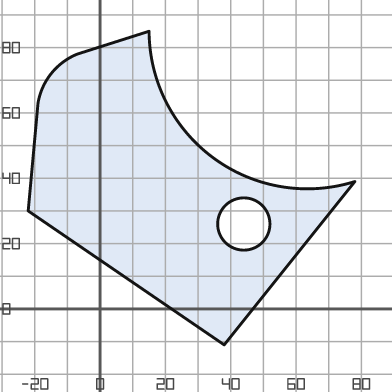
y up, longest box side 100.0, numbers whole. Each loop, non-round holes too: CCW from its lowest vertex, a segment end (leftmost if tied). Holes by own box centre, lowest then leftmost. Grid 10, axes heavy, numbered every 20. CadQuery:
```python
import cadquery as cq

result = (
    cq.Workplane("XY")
    .moveTo(38.0, -11.0)
    .lineTo(78.0, 39.0)
    .threePointArc((35.0, 46.0), (15.0, 85.0))
    .lineTo(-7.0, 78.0)
    .threePointArc((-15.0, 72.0), (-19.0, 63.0))
    .lineTo(-22.0, 30.0)
    .close()
    .moveTo(44.0, 26.0)
    .circle(8.0)
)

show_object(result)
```